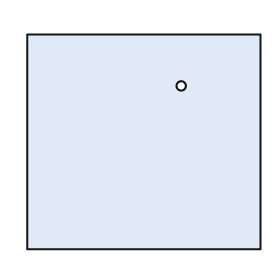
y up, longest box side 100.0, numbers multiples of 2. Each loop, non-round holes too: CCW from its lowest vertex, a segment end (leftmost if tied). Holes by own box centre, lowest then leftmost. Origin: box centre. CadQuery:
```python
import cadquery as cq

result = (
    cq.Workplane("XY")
    .moveTo(-50.0, -46.0)
    .lineTo(50.0, -46.0)
    .lineTo(50.0, 46.0)
    .lineTo(-50.0, 46.0)
    .close()
    .moveTo(16.0, 24.0)
    .circle(2.0)
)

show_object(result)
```